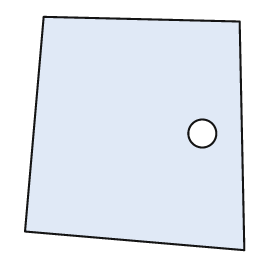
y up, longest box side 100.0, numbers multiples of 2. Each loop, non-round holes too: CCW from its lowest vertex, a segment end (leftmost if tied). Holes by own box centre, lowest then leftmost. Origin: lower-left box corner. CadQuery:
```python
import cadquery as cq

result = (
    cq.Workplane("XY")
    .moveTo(94.0, 0.0)
    .lineTo(92.0, 98.0)
    .lineTo(8.0, 100.0)
    .lineTo(0.0, 8.0)
    .close()
    .moveTo(76.0, 50.0)
    .circle(6.0)
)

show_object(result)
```